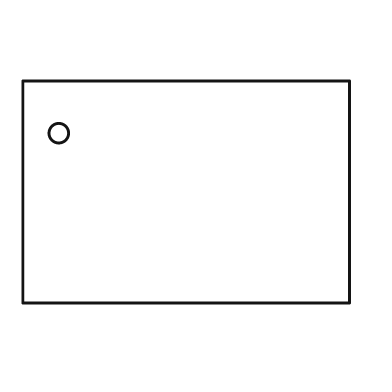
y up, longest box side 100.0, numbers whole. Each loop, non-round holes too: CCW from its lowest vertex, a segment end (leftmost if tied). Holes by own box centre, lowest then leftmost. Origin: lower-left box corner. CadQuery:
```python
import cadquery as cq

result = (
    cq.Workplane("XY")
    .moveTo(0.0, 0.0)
    .lineTo(100.0, 0.0)
    .lineTo(100.0, 68.0)
    .lineTo(0.0, 68.0)
    .close()
    .moveTo(11.0, 52.0)
    .circle(3.0)
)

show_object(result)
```